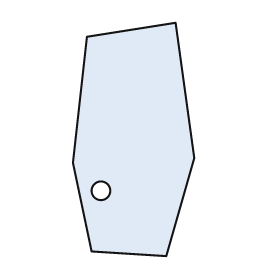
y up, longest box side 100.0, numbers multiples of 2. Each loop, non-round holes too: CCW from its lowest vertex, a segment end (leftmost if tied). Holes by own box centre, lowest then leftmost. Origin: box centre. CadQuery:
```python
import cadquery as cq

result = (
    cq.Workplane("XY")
    .moveTo(14.0, -50.0)
    .lineTo(26.0, -8.0)
    .lineTo(18.0, 50.0)
    .lineTo(-20.0, 44.0)
    .lineTo(-26.0, -10.0)
    .lineTo(-18.0, -48.0)
    .close()
    .moveTo(-14.0, -22.0)
    .circle(4.0)
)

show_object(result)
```